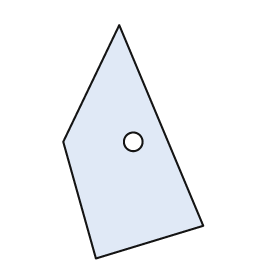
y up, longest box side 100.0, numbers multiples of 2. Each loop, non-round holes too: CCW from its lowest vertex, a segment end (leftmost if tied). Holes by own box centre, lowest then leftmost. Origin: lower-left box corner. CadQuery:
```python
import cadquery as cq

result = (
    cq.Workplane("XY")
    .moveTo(14.0, 0.0)
    .lineTo(60.0, 14.0)
    .lineTo(24.0, 100.0)
    .lineTo(0.0, 50.0)
    .close()
    .moveTo(30.0, 50.0)
    .circle(4.0)
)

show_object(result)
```